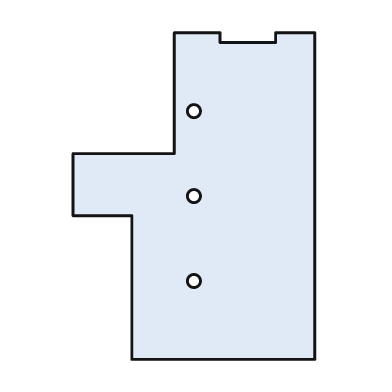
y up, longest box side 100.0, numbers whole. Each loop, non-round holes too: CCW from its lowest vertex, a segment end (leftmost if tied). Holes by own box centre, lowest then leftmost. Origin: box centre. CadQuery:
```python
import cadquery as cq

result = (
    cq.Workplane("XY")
    .moveTo(-19.0, -50.0)
    .lineTo(37.0, -50.0)
    .lineTo(37.0, 50.0)
    .lineTo(25.0, 50.0)
    .lineTo(25.0, 47.0)
    .lineTo(8.0, 47.0)
    .lineTo(8.0, 50.0)
    .lineTo(-6.0, 50.0)
    .lineTo(-6.0, 13.0)
    .lineTo(-37.0, 13.0)
    .lineTo(-37.0, -6.0)
    .lineTo(-19.0, -6.0)
    .close()
    .moveTo(0.0, -26.0)
    .circle(2.0)
    .moveTo(0.0, 0.0)
    .circle(2.0)
    .moveTo(0.0, 26.0)
    .circle(2.0)
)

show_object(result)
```